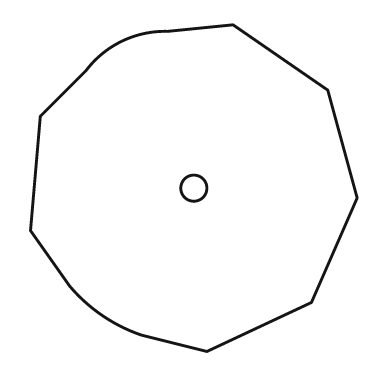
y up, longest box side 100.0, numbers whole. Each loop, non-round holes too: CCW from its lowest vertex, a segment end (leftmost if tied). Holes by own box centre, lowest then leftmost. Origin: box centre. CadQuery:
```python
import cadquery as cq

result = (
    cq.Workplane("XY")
    .moveTo(4.0, -50.0)
    .lineTo(36.0, -35.0)
    .lineTo(50.0, -3.0)
    .lineTo(41.0, 30.0)
    .lineTo(12.0, 50.0)
    .lineTo(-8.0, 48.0)
    .threePointArc((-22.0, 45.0), (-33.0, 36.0))
    .lineTo(-47.0, 22.0)
    .lineTo(-50.0, -13.0)
    .lineTo(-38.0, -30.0)
    .threePointArc((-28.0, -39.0), (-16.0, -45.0))
    .close()
    .moveTo(0.0, 0.0)
    .circle(4.0)
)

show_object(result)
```